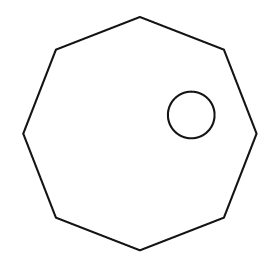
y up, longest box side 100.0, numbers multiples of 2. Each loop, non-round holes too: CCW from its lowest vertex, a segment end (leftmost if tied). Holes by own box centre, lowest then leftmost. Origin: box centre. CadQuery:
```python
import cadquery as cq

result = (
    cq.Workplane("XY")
    .moveTo(0.0, -50.0)
    .lineTo(36.0, -36.0)
    .lineTo(50.0, 0.0)
    .lineTo(36.0, 36.0)
    .lineTo(0.0, 50.0)
    .lineTo(-36.0, 36.0)
    .lineTo(-50.0, 0.0)
    .lineTo(-36.0, -36.0)
    .close()
    .moveTo(22.0, 8.0)
    .circle(10.0)
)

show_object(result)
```